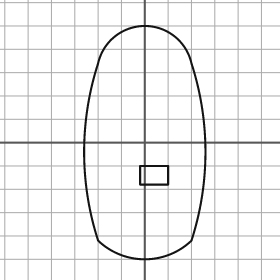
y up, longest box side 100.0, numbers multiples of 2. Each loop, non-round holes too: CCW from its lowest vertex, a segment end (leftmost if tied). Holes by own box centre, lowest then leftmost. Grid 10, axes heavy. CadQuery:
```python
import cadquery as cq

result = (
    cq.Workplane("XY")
    .moveTo(-20.0, -42.0)
    .threePointArc((0.0, -50.0), (20.0, -42.0))
    .threePointArc((26.0, -4.0), (20.0, 34.0))
    .threePointArc((0.0, 50.0), (-20.0, 34.0))
    .threePointArc((-26.0, -4.0), (-20.0, -42.0))
    .close()
    .moveTo(-2.0, -18.0)
    .lineTo(10.0, -18.0)
    .lineTo(10.0, -10.0)
    .lineTo(-2.0, -10.0)
    .close()
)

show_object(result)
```